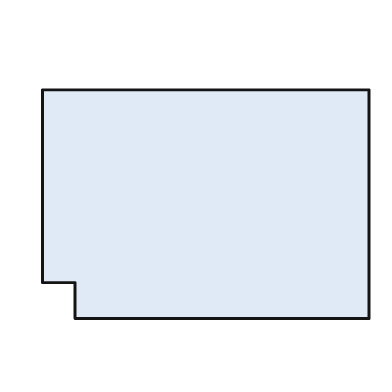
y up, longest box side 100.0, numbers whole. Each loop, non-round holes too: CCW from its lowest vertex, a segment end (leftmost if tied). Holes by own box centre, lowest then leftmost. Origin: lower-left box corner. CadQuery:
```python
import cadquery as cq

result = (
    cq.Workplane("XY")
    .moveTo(10.0, 0.0)
    .lineTo(100.0, 0.0)
    .lineTo(100.0, 70.0)
    .lineTo(0.0, 70.0)
    .lineTo(0.0, 11.0)
    .lineTo(10.0, 11.0)
    .close()
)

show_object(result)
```